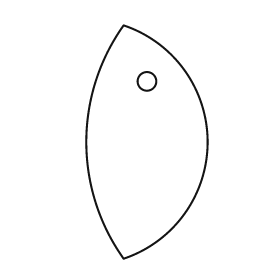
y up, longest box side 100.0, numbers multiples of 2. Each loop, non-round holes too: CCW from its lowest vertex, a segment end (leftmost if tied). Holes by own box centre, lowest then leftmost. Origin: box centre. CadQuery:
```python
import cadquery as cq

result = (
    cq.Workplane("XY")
    .moveTo(-10.0, -50.0)
    .threePointArc((26.0, 0.0), (-10.0, 50.0))
    .threePointArc((-26.0, 0.0), (-10.0, -50.0))
    .close()
    .moveTo(0.0, 26.0)
    .circle(4.0)
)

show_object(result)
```